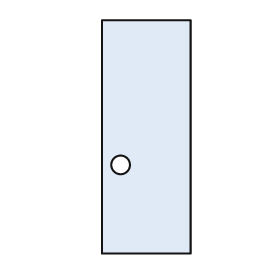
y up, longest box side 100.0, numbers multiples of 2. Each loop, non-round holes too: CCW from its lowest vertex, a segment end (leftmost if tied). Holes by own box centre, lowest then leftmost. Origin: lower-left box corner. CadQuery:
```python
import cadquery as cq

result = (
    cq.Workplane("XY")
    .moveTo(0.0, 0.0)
    .lineTo(38.0, 0.0)
    .lineTo(38.0, 100.0)
    .lineTo(0.0, 100.0)
    .close()
    .moveTo(8.0, 38.0)
    .circle(4.0)
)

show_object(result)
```